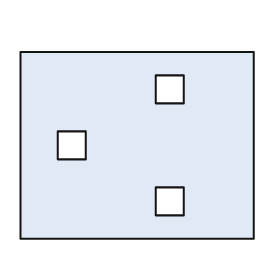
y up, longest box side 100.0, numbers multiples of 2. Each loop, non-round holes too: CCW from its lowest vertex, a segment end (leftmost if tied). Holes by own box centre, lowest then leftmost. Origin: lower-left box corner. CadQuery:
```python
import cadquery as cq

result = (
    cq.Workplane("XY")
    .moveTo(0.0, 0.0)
    .lineTo(100.0, 0.0)
    .lineTo(100.0, 80.0)
    .lineTo(0.0, 80.0)
    .close()
    .moveTo(58.0, 10.0)
    .lineTo(70.0, 10.0)
    .lineTo(70.0, 22.0)
    .lineTo(58.0, 22.0)
    .close()
    .moveTo(16.0, 34.0)
    .lineTo(28.0, 34.0)
    .lineTo(28.0, 46.0)
    .lineTo(16.0, 46.0)
    .close()
    .moveTo(58.0, 58.0)
    .lineTo(70.0, 58.0)
    .lineTo(70.0, 70.0)
    .lineTo(58.0, 70.0)
    .close()
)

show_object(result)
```